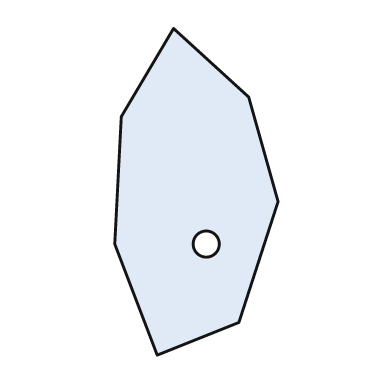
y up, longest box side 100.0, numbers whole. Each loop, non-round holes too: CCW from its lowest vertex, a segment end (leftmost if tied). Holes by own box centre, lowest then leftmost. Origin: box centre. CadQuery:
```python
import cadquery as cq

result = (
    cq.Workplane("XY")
    .moveTo(-12.0, -50.0)
    .lineTo(13.0, -40.0)
    .lineTo(25.0, -3.0)
    .lineTo(16.0, 29.0)
    .lineTo(-7.0, 50.0)
    .lineTo(-23.0, 23.0)
    .lineTo(-25.0, -16.0)
    .close()
    .moveTo(3.0, -16.0)
    .circle(4.0)
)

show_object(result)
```